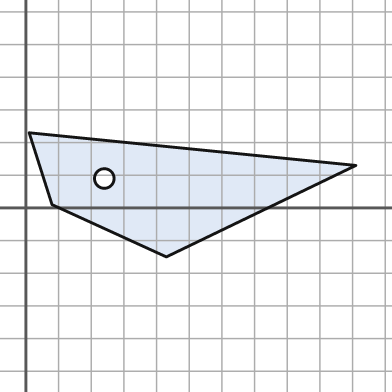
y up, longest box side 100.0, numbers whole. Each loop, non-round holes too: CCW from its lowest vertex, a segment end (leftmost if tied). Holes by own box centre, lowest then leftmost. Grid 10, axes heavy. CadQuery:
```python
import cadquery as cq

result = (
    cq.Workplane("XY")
    .moveTo(43.0, -15.0)
    .lineTo(101.0, 13.0)
    .lineTo(1.0, 23.0)
    .lineTo(8.0, 1.0)
    .close()
    .moveTo(24.0, 9.0)
    .circle(3.0)
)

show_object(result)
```